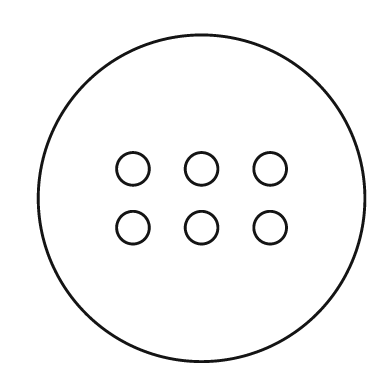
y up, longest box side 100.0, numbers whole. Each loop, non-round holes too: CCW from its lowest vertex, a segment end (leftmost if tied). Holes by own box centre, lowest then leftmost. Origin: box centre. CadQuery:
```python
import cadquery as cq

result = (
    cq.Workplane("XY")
    .moveTo(0.0, 0.0)
    .circle(50.0)
    .moveTo(-21.0, -9.0)
    .circle(5.0)
    .moveTo(0.0, -9.0)
    .circle(5.0)
    .moveTo(21.0, -9.0)
    .circle(5.0)
    .moveTo(-21.0, 9.0)
    .circle(5.0)
    .moveTo(0.0, 9.0)
    .circle(5.0)
    .moveTo(21.0, 9.0)
    .circle(5.0)
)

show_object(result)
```